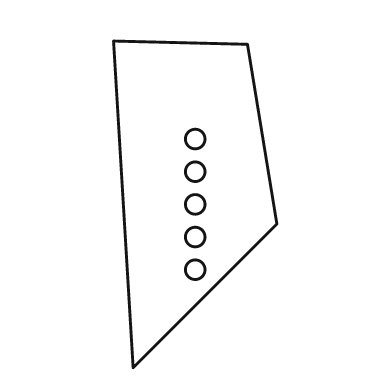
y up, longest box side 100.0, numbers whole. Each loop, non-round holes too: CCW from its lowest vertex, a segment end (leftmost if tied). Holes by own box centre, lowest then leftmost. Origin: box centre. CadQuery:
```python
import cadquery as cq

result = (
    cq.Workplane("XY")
    .moveTo(-19.0, -50.0)
    .lineTo(25.0, -6.0)
    .lineTo(16.0, 49.0)
    .lineTo(-25.0, 50.0)
    .close()
    .moveTo(0.0, -20.0)
    .circle(3.0)
    .moveTo(0.0, -10.0)
    .circle(3.0)
    .moveTo(0.0, 0.0)
    .circle(3.0)
    .moveTo(0.0, 10.0)
    .circle(3.0)
    .moveTo(0.0, 20.0)
    .circle(3.0)
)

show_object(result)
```